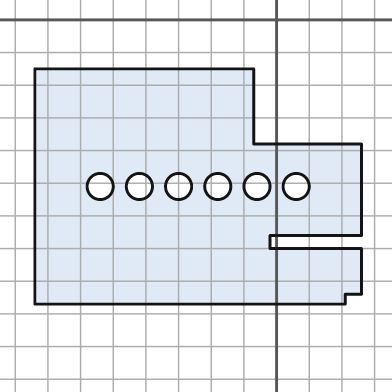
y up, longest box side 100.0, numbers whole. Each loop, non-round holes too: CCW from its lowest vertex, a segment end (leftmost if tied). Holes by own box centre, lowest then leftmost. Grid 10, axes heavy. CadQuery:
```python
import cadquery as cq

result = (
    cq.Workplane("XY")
    .moveTo(-74.0, -87.0)
    .lineTo(21.0, -87.0)
    .lineTo(21.0, -84.0)
    .lineTo(26.0, -84.0)
    .lineTo(26.0, -70.0)
    .lineTo(-2.0, -70.0)
    .lineTo(-2.0, -66.0)
    .lineTo(26.0, -66.0)
    .lineTo(26.0, -38.0)
    .lineTo(-7.0, -38.0)
    .lineTo(-7.0, -15.0)
    .lineTo(-74.0, -15.0)
    .close()
    .moveTo(-54.0, -51.0)
    .circle(4.0)
    .moveTo(-42.0, -51.0)
    .circle(4.0)
    .moveTo(-30.0, -51.0)
    .circle(4.0)
    .moveTo(-18.0, -51.0)
    .circle(4.0)
    .moveTo(-6.0, -51.0)
    .circle(4.0)
    .moveTo(6.0, -51.0)
    .circle(4.0)
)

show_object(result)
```